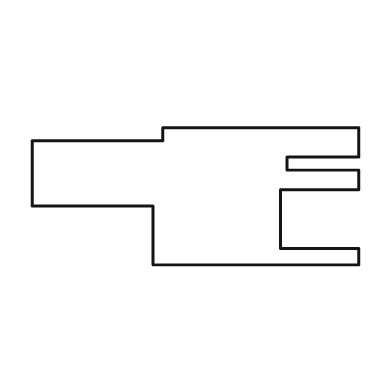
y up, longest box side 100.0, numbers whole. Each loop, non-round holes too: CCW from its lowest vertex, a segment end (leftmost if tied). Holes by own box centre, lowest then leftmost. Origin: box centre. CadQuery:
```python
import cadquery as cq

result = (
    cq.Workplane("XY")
    .moveTo(-13.0, -21.0)
    .lineTo(50.0, -21.0)
    .lineTo(50.0, -16.0)
    .lineTo(26.0, -16.0)
    .lineTo(26.0, 2.0)
    .lineTo(50.0, 2.0)
    .lineTo(50.0, 8.0)
    .lineTo(28.0, 8.0)
    .lineTo(28.0, 12.0)
    .lineTo(50.0, 12.0)
    .lineTo(50.0, 21.0)
    .lineTo(-10.0, 21.0)
    .lineTo(-10.0, 17.0)
    .lineTo(-50.0, 17.0)
    .lineTo(-50.0, -3.0)
    .lineTo(-13.0, -3.0)
    .close()
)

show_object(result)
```